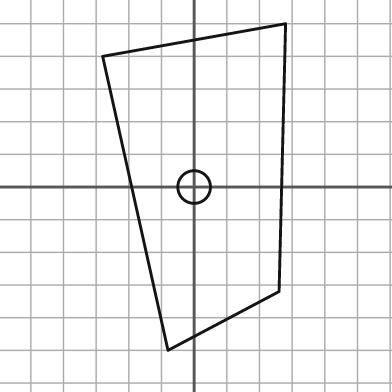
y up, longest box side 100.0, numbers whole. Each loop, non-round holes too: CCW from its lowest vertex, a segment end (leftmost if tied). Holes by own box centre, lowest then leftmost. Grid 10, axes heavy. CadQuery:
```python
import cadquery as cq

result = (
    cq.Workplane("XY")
    .moveTo(-8.0, -50.0)
    .lineTo(26.0, -32.0)
    .lineTo(28.0, 50.0)
    .lineTo(-28.0, 40.0)
    .close()
    .moveTo(0.0, 0.0)
    .circle(5.0)
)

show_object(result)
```